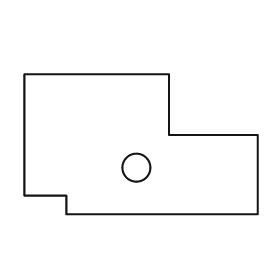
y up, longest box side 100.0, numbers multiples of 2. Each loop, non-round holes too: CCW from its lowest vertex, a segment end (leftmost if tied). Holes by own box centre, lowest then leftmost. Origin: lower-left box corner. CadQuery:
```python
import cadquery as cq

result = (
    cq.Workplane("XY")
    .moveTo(18.0, 0.0)
    .lineTo(100.0, 0.0)
    .lineTo(100.0, 34.0)
    .lineTo(62.0, 34.0)
    .lineTo(62.0, 60.0)
    .lineTo(0.0, 60.0)
    .lineTo(0.0, 8.0)
    .lineTo(18.0, 8.0)
    .close()
    .moveTo(48.0, 20.0)
    .circle(6.0)
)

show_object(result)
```